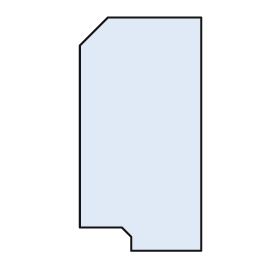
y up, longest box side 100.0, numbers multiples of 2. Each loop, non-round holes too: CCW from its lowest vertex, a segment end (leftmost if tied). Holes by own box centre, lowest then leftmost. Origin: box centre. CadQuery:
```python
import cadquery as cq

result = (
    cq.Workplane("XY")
    .moveTo(-4.0, -50.0)
    .lineTo(26.0, -50.0)
    .lineTo(26.0, 50.0)
    .lineTo(-14.0, 50.0)
    .lineTo(-26.0, 38.0)
    .lineTo(-26.0, -40.0)
    .lineTo(-8.0, -40.0)
    .lineTo(-4.0, -44.0)
    .close()
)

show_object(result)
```